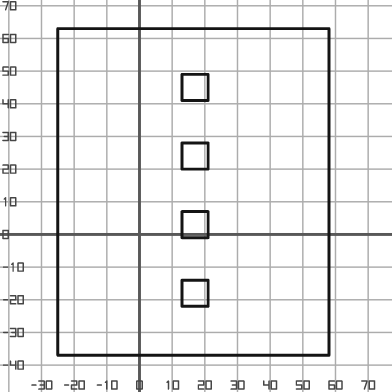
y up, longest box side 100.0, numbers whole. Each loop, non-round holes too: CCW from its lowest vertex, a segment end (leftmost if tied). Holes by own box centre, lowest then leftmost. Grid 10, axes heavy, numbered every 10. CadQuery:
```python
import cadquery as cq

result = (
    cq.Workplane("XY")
    .moveTo(-25.0, -37.0)
    .lineTo(58.0, -37.0)
    .lineTo(58.0, 63.0)
    .lineTo(-25.0, 63.0)
    .close()
    .moveTo(13.0, -22.0)
    .lineTo(21.0, -22.0)
    .lineTo(21.0, -14.0)
    .lineTo(13.0, -14.0)
    .close()
    .moveTo(13.0, -1.0)
    .lineTo(21.0, -1.0)
    .lineTo(21.0, 7.0)
    .lineTo(13.0, 7.0)
    .close()
    .moveTo(13.0, 20.0)
    .lineTo(21.0, 20.0)
    .lineTo(21.0, 28.0)
    .lineTo(13.0, 28.0)
    .close()
    .moveTo(13.0, 41.0)
    .lineTo(21.0, 41.0)
    .lineTo(21.0, 49.0)
    .lineTo(13.0, 49.0)
    .close()
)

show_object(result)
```